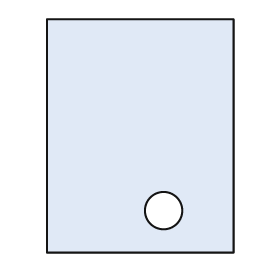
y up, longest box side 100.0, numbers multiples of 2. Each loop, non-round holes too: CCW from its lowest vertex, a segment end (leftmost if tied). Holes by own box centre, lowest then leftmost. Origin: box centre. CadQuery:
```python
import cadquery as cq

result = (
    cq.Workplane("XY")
    .moveTo(-40.0, -50.0)
    .lineTo(40.0, -50.0)
    .lineTo(40.0, 50.0)
    .lineTo(-40.0, 50.0)
    .close()
    .moveTo(10.0, -32.0)
    .circle(8.0)
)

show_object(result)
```